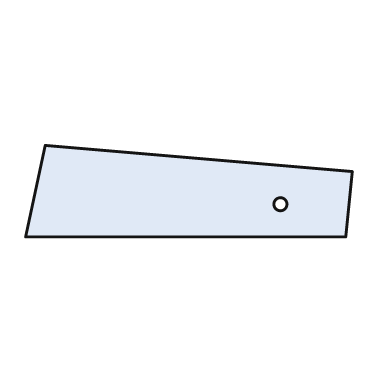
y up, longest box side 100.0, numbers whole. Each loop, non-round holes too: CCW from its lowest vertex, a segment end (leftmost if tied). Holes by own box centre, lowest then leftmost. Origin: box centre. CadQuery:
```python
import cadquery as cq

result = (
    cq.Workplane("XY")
    .moveTo(-50.0, -14.0)
    .lineTo(48.0, -14.0)
    .lineTo(50.0, 6.0)
    .lineTo(-44.0, 14.0)
    .close()
    .moveTo(28.0, -4.0)
    .circle(2.0)
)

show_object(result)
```